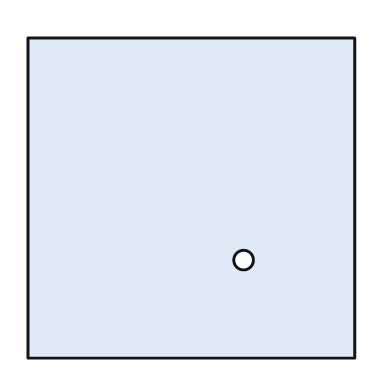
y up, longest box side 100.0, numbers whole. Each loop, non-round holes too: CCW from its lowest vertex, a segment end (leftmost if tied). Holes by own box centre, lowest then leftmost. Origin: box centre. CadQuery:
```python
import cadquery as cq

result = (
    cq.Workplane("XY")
    .moveTo(-50.0, -49.0)
    .lineTo(50.0, -49.0)
    .lineTo(50.0, 49.0)
    .lineTo(-50.0, 49.0)
    .close()
    .moveTo(16.0, -19.0)
    .circle(3.0)
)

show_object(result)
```